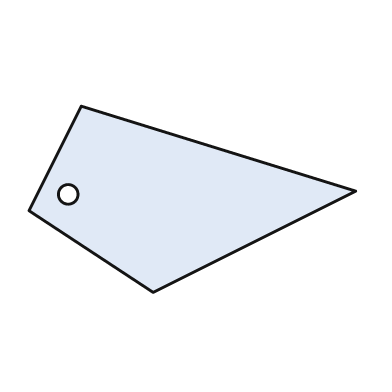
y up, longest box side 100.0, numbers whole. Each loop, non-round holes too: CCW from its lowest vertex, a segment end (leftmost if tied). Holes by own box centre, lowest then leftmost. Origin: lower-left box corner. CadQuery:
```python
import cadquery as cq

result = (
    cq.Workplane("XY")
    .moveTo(38.0, 0.0)
    .lineTo(100.0, 31.0)
    .lineTo(16.0, 57.0)
    .lineTo(0.0, 25.0)
    .close()
    .moveTo(12.0, 30.0)
    .circle(3.0)
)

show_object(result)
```